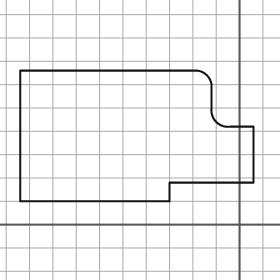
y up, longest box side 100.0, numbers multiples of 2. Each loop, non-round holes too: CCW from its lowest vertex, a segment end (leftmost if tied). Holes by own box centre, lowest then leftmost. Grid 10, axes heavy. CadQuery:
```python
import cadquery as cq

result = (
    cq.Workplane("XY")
    .moveTo(-94.0, 10.0)
    .lineTo(-30.0, 10.0)
    .lineTo(-30.0, 18.0)
    .lineTo(6.0, 18.0)
    .lineTo(6.0, 42.0)
    .lineTo(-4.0, 42.0)
    .threePointArc((-10.0, 44.0), (-12.0, 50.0))
    .lineTo(-12.0, 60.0)
    .threePointArc((-14.0, 64.0), (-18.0, 66.0))
    .lineTo(-94.0, 66.0)
    .close()
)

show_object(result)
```